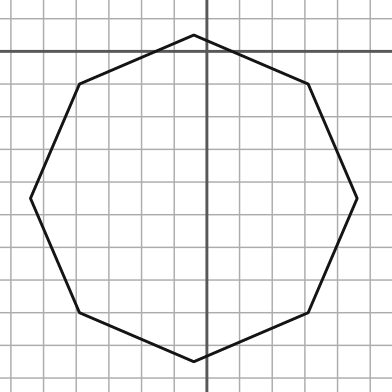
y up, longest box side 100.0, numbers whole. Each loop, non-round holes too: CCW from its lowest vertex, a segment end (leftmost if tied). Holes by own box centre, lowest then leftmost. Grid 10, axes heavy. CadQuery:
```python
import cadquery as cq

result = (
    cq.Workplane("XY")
    .moveTo(-4.0, -95.0)
    .lineTo(31.0, -80.0)
    .lineTo(46.0, -45.0)
    .lineTo(31.0, -10.0)
    .lineTo(-4.0, 5.0)
    .lineTo(-39.0, -10.0)
    .lineTo(-54.0, -45.0)
    .lineTo(-39.0, -80.0)
    .close()
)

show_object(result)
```